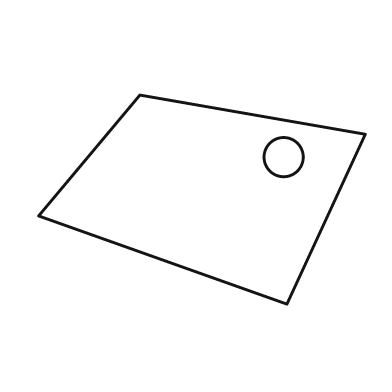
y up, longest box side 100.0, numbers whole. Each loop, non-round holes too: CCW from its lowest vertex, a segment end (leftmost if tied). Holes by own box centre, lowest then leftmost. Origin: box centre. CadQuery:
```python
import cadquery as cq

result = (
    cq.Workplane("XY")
    .moveTo(26.0, -32.0)
    .lineTo(50.0, 20.0)
    .lineTo(-19.0, 32.0)
    .lineTo(-50.0, -5.0)
    .close()
    .moveTo(25.0, 13.0)
    .circle(6.0)
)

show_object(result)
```